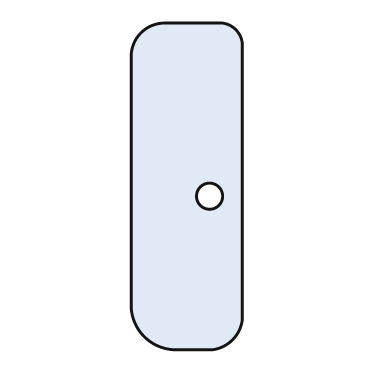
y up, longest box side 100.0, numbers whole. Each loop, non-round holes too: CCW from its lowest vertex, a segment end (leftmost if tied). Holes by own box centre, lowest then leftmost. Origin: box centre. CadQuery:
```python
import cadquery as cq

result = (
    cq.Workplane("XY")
    .moveTo(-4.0, -50.0)
    .lineTo(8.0, -50.0)
    .threePointArc((14.0, -47.0), (17.0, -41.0))
    .lineTo(17.0, 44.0)
    .threePointArc((15.0, 48.0), (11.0, 50.0))
    .lineTo(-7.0, 50.0)
    .threePointArc((-14.0, 47.0), (-17.0, 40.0))
    .lineTo(-17.0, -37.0)
    .threePointArc((-13.0, -46.0), (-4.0, -50.0))
    .close()
    .moveTo(7.0, -3.0)
    .circle(4.0)
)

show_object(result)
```